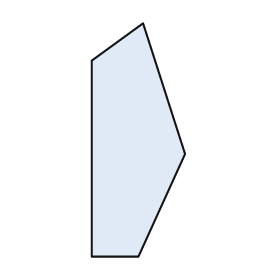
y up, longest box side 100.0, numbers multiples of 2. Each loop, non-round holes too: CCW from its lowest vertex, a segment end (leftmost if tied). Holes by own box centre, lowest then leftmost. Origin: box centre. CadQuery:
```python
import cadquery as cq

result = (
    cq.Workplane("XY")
    .moveTo(-20.0, -50.0)
    .lineTo(0.0, -50.0)
    .lineTo(20.0, -6.0)
    .lineTo(2.0, 50.0)
    .lineTo(-20.0, 34.0)
    .close()
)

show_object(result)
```